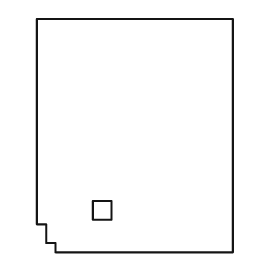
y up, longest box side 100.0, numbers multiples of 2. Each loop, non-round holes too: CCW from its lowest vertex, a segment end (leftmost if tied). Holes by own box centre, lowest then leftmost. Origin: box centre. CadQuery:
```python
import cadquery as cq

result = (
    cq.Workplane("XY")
    .moveTo(-34.0, -50.0)
    .lineTo(42.0, -50.0)
    .lineTo(42.0, 50.0)
    .lineTo(-42.0, 50.0)
    .lineTo(-42.0, -38.0)
    .lineTo(-38.0, -38.0)
    .lineTo(-38.0, -46.0)
    .lineTo(-34.0, -46.0)
    .close()
    .moveTo(-18.0, -36.0)
    .lineTo(-10.0, -36.0)
    .lineTo(-10.0, -28.0)
    .lineTo(-18.0, -28.0)
    .close()
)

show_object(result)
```